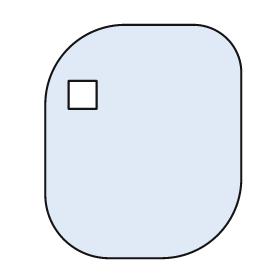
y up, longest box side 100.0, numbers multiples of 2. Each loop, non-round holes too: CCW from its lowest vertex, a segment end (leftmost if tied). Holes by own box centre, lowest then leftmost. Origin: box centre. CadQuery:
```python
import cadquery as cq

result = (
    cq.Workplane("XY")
    .moveTo(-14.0, -50.0)
    .lineTo(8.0, -50.0)
    .threePointArc((32.0, -40.0), (42.0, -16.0))
    .lineTo(42.0, 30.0)
    .threePointArc((36.0, 44.0), (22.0, 50.0))
    .lineTo(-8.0, 50.0)
    .threePointArc((-32.0, 40.0), (-42.0, 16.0))
    .lineTo(-42.0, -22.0)
    .threePointArc((-34.0, -42.0), (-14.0, -50.0))
    .close()
    .moveTo(-32.0, 14.0)
    .lineTo(-20.0, 14.0)
    .lineTo(-20.0, 26.0)
    .lineTo(-32.0, 26.0)
    .close()
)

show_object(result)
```